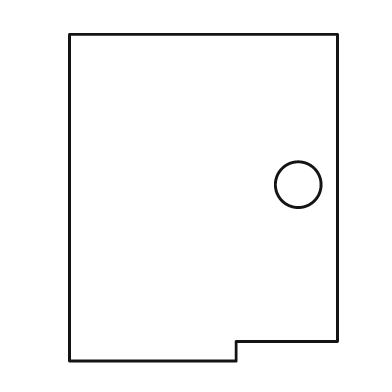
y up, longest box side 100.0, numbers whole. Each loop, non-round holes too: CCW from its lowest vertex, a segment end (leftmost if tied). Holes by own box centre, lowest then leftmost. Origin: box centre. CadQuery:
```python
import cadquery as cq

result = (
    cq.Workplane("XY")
    .moveTo(-41.0, -50.0)
    .lineTo(10.0, -50.0)
    .lineTo(10.0, -44.0)
    .lineTo(41.0, -44.0)
    .lineTo(41.0, 50.0)
    .lineTo(-41.0, 50.0)
    .close()
    .moveTo(29.0, 4.0)
    .circle(7.0)
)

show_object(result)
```